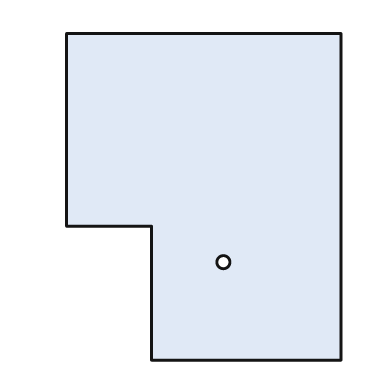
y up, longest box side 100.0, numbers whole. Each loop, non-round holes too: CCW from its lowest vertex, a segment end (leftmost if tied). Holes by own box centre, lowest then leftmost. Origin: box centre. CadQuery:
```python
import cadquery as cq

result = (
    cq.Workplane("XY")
    .moveTo(-16.0, -50.0)
    .lineTo(42.0, -50.0)
    .lineTo(42.0, 50.0)
    .lineTo(-42.0, 50.0)
    .lineTo(-42.0, -9.0)
    .lineTo(-16.0, -9.0)
    .close()
    .moveTo(6.0, -20.0)
    .circle(2.0)
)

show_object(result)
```